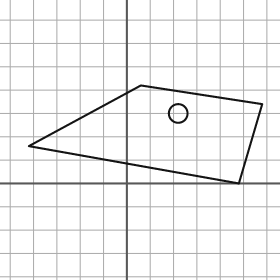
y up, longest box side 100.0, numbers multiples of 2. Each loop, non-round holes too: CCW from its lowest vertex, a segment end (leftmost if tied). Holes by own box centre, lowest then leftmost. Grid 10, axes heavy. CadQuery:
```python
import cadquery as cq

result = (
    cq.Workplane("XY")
    .moveTo(48.0, 0.0)
    .lineTo(58.0, 34.0)
    .lineTo(6.0, 42.0)
    .lineTo(-42.0, 16.0)
    .close()
    .moveTo(22.0, 30.0)
    .circle(4.0)
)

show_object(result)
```